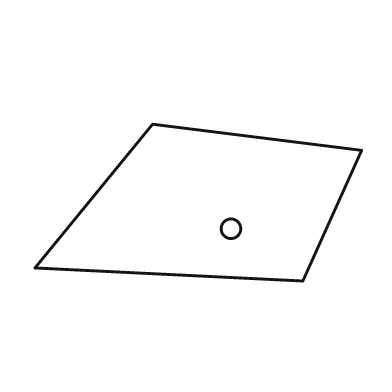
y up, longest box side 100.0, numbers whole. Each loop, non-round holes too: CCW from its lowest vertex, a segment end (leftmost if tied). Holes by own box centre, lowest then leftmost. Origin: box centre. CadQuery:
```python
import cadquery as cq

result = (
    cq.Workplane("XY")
    .moveTo(32.0, -24.0)
    .lineTo(50.0, 16.0)
    .lineTo(-14.0, 24.0)
    .lineTo(-50.0, -20.0)
    .close()
    .moveTo(10.0, -8.0)
    .circle(3.0)
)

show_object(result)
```